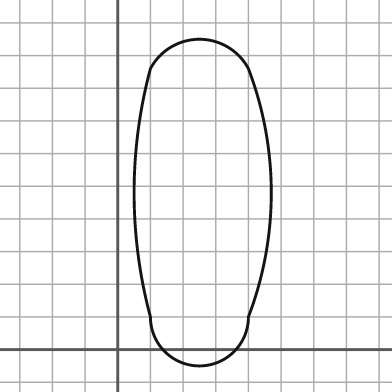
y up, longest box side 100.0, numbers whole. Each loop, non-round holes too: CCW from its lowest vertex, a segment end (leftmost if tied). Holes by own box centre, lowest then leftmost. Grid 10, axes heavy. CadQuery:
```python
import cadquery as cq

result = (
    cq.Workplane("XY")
    .moveTo(10.0, 10.0)
    .threePointArc((25.0, -5.0), (40.0, 10.0))
    .threePointArc((47.0, 48.0), (40.0, 86.0))
    .threePointArc((25.0, 95.0), (10.0, 86.0))
    .threePointArc((5.0, 48.0), (10.0, 10.0))
    .close()
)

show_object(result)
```